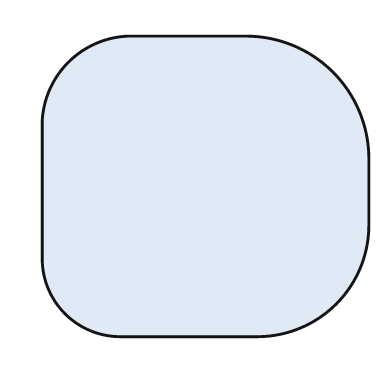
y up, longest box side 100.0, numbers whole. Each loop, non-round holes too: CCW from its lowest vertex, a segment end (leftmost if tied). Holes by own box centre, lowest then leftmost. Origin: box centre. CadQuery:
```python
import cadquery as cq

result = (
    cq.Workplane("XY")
    .moveTo(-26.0, -46.0)
    .lineTo(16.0, -46.0)
    .threePointArc((40.0, -36.0), (50.0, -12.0))
    .lineTo(50.0, 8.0)
    .threePointArc((39.0, 35.0), (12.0, 46.0))
    .lineTo(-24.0, 46.0)
    .threePointArc((-42.0, 38.0), (-50.0, 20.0))
    .lineTo(-50.0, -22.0)
    .threePointArc((-43.0, -39.0), (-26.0, -46.0))
    .close()
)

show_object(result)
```